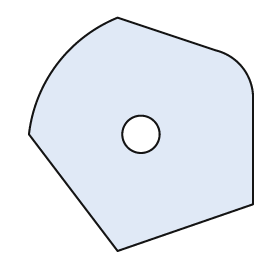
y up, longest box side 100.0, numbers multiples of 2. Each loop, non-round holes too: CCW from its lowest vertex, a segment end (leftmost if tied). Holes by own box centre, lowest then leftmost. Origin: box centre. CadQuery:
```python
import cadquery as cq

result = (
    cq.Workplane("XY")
    .moveTo(-10.0, -50.0)
    .lineTo(48.0, -30.0)
    .lineTo(48.0, 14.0)
    .threePointArc((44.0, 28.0), (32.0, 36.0))
    .lineTo(-10.0, 50.0)
    .threePointArc((-36.0, 30.0), (-48.0, 0.0))
    .close()
    .moveTo(0.0, 0.0)
    .circle(8.0)
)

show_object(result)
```